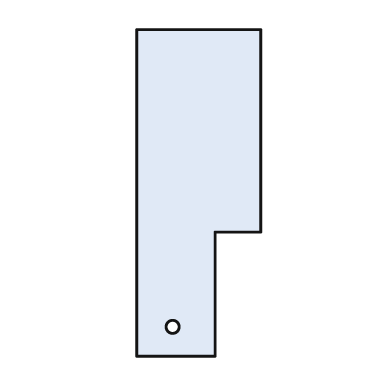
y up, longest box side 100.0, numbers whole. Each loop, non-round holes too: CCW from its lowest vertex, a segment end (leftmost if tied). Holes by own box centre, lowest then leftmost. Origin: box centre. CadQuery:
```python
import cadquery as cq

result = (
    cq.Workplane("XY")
    .moveTo(-19.0, -50.0)
    .lineTo(5.0, -50.0)
    .lineTo(5.0, -12.0)
    .lineTo(19.0, -12.0)
    .lineTo(19.0, 50.0)
    .lineTo(-19.0, 50.0)
    .close()
    .moveTo(-8.0, -41.0)
    .circle(2.0)
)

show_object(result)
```